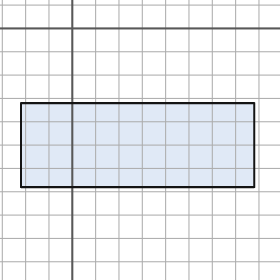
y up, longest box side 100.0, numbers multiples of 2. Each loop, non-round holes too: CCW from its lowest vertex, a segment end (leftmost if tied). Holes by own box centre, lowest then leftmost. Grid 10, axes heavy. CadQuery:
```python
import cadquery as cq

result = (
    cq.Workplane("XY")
    .moveTo(-22.0, -68.0)
    .lineTo(78.0, -68.0)
    .lineTo(78.0, -32.0)
    .lineTo(-22.0, -32.0)
    .close()
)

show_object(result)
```